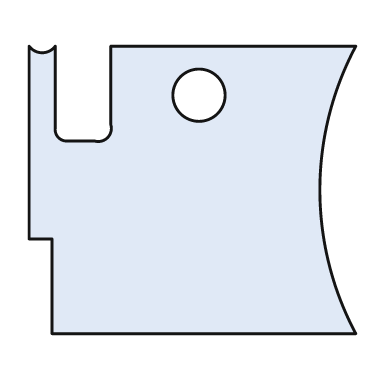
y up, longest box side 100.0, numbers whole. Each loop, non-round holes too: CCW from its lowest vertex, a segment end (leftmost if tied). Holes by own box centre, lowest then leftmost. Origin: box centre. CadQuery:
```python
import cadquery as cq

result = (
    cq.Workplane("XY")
    .moveTo(-43.0, -44.0)
    .lineTo(50.0, -44.0)
    .threePointArc((39.0, 0.0), (50.0, 44.0))
    .lineTo(-25.0, 44.0)
    .lineTo(-25.0, 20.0)
    .threePointArc((-26.0, 16.0), (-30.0, 15.0))
    .lineTo(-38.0, 15.0)
    .threePointArc((-41.0, 16.0), (-42.0, 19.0))
    .lineTo(-42.0, 44.0)
    .threePointArc((-46.0, 42.0), (-50.0, 44.0))
    .lineTo(-50.0, -15.0)
    .lineTo(-43.0, -15.0)
    .close()
    .moveTo(2.0, 29.0)
    .circle(8.0)
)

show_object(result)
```